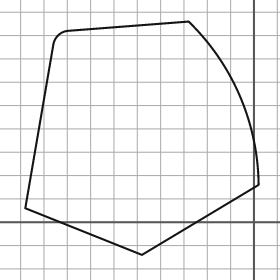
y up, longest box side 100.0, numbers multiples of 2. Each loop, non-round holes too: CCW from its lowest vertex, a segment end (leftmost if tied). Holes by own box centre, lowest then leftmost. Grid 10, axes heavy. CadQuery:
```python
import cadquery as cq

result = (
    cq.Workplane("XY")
    .moveTo(-48.0, -14.0)
    .lineTo(2.0, 16.0)
    .threePointArc((-6.0, 54.0), (-28.0, 86.0))
    .lineTo(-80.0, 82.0)
    .threePointArc((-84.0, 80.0), (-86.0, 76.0))
    .lineTo(-98.0, 6.0)
    .close()
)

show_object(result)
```